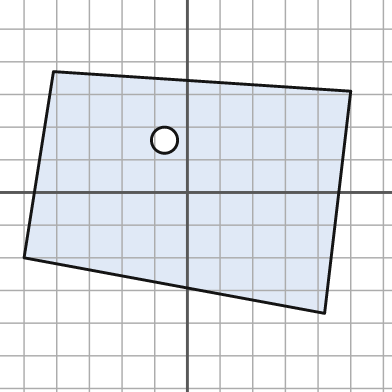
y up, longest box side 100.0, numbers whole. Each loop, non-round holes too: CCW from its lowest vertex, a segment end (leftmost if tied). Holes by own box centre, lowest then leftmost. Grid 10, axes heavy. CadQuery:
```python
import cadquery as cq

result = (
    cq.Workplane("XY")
    .moveTo(42.0, -37.0)
    .lineTo(50.0, 31.0)
    .lineTo(-41.0, 37.0)
    .lineTo(-50.0, -20.0)
    .close()
    .moveTo(-7.0, 16.0)
    .circle(4.0)
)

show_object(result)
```